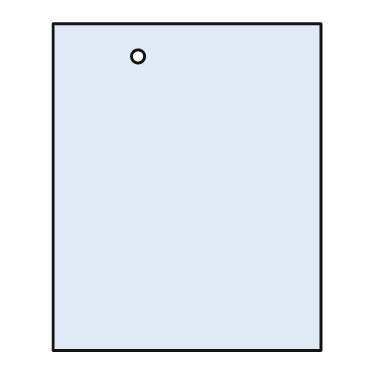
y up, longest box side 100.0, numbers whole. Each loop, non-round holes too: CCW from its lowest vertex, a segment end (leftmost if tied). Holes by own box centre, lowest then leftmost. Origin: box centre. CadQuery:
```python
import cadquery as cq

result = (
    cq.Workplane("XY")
    .moveTo(-41.0, -50.0)
    .lineTo(41.0, -50.0)
    .lineTo(41.0, 50.0)
    .lineTo(-41.0, 50.0)
    .close()
    .moveTo(-15.0, 40.0)
    .circle(2.0)
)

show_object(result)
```